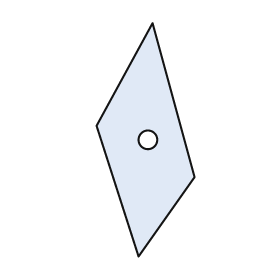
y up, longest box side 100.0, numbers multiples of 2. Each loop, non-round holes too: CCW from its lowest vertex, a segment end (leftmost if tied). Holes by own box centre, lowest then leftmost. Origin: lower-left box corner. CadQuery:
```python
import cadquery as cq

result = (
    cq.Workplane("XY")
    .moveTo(18.0, 0.0)
    .lineTo(42.0, 34.0)
    .lineTo(24.0, 100.0)
    .lineTo(0.0, 56.0)
    .close()
    .moveTo(22.0, 50.0)
    .circle(4.0)
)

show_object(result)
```